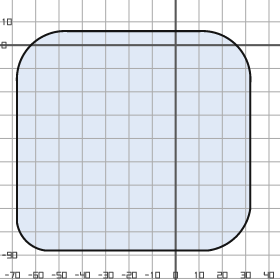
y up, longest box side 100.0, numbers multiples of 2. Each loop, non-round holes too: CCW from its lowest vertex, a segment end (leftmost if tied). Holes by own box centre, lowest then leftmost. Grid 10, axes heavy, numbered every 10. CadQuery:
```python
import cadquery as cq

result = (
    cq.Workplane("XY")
    .moveTo(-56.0, -88.0)
    .lineTo(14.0, -88.0)
    .threePointArc((26.0, -82.0), (32.0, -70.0))
    .lineTo(32.0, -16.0)
    .threePointArc((26.0, 0.0), (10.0, 6.0))
    .lineTo(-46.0, 6.0)
    .threePointArc((-62.0, 0.0), (-68.0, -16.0))
    .lineTo(-68.0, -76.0)
    .threePointArc((-64.0, -84.0), (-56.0, -88.0))
    .close()
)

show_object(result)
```